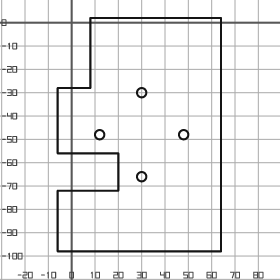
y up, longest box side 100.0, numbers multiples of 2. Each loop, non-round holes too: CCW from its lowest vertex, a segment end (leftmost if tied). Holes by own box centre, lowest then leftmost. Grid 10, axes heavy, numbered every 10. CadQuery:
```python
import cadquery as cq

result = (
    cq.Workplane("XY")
    .moveTo(-6.0, -98.0)
    .lineTo(64.0, -98.0)
    .lineTo(64.0, 2.0)
    .lineTo(8.0, 2.0)
    .lineTo(8.0, -28.0)
    .lineTo(-6.0, -28.0)
    .lineTo(-6.0, -56.0)
    .lineTo(20.0, -56.0)
    .lineTo(20.0, -72.0)
    .lineTo(-6.0, -72.0)
    .close()
    .moveTo(30.0, -66.0)
    .circle(2.0)
    .moveTo(12.0, -48.0)
    .circle(2.0)
    .moveTo(48.0, -48.0)
    .circle(2.0)
    .moveTo(30.0, -30.0)
    .circle(2.0)
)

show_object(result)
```